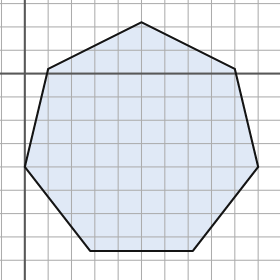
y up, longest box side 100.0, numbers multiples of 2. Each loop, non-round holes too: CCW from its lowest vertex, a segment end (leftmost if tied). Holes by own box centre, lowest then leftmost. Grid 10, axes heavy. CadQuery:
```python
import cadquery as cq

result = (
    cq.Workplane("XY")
    .moveTo(28.0, -76.0)
    .lineTo(72.0, -76.0)
    .lineTo(100.0, -40.0)
    .lineTo(90.0, 2.0)
    .lineTo(50.0, 22.0)
    .lineTo(10.0, 2.0)
    .lineTo(0.0, -40.0)
    .close()
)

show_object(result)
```